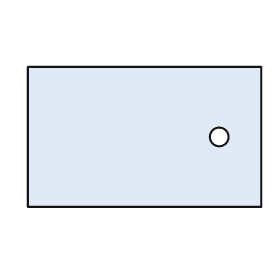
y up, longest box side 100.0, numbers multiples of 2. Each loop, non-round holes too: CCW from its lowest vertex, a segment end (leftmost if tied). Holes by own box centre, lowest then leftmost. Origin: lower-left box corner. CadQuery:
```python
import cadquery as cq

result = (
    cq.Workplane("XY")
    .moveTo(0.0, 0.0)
    .lineTo(100.0, 0.0)
    .lineTo(100.0, 60.0)
    .lineTo(0.0, 60.0)
    .close()
    .moveTo(82.0, 30.0)
    .circle(4.0)
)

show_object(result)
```